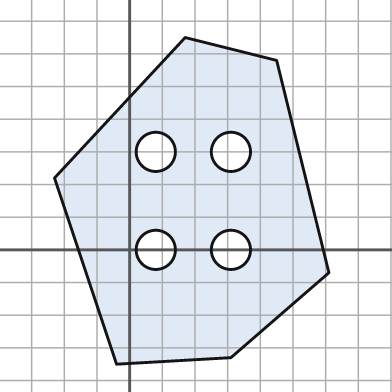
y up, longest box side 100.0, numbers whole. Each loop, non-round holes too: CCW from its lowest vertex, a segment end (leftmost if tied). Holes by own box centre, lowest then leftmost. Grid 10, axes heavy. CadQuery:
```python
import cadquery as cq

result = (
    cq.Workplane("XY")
    .moveTo(-4.0, -35.0)
    .lineTo(31.0, -33.0)
    .lineTo(61.0, -7.0)
    .lineTo(45.0, 58.0)
    .lineTo(17.0, 65.0)
    .lineTo(-23.0, 22.0)
    .close()
    .moveTo(8.0, 0.0)
    .circle(6.0)
    .moveTo(31.0, 0.0)
    .circle(6.0)
    .moveTo(8.0, 30.0)
    .circle(6.0)
    .moveTo(31.0, 30.0)
    .circle(6.0)
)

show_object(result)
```